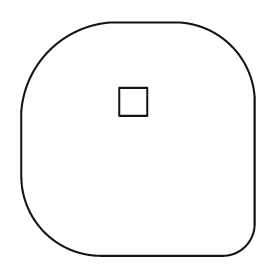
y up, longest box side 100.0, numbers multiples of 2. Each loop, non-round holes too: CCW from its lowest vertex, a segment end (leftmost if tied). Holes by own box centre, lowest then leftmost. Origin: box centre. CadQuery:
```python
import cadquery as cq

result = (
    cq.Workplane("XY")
    .moveTo(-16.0, -50.0)
    .lineTo(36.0, -50.0)
    .threePointArc((46.0, -46.0), (50.0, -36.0))
    .lineTo(50.0, 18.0)
    .threePointArc((40.0, 40.0), (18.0, 50.0))
    .lineTo(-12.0, 50.0)
    .threePointArc((-38.0, 38.0), (-50.0, 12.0))
    .lineTo(-50.0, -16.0)
    .threePointArc((-40.0, -40.0), (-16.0, -50.0))
    .close()
    .moveTo(-8.0, 10.0)
    .lineTo(4.0, 10.0)
    .lineTo(4.0, 22.0)
    .lineTo(-8.0, 22.0)
    .close()
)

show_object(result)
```